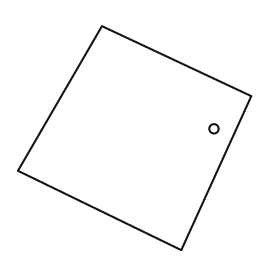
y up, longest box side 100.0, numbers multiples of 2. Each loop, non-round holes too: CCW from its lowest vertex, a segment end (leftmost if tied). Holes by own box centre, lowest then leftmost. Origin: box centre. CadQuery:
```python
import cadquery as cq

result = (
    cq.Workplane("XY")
    .moveTo(20.0, -48.0)
    .lineTo(50.0, 18.0)
    .lineTo(-14.0, 48.0)
    .lineTo(-50.0, -14.0)
    .close()
    .moveTo(34.0, 4.0)
    .circle(2.0)
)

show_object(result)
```